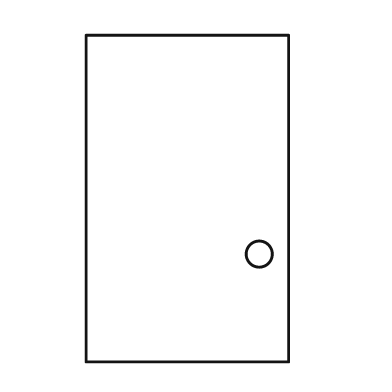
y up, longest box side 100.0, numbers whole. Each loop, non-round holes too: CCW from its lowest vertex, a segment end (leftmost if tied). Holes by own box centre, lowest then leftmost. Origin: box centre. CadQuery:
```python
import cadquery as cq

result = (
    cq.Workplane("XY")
    .moveTo(-31.0, -50.0)
    .lineTo(31.0, -50.0)
    .lineTo(31.0, 50.0)
    .lineTo(-31.0, 50.0)
    .close()
    .moveTo(22.0, -17.0)
    .circle(4.0)
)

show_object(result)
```